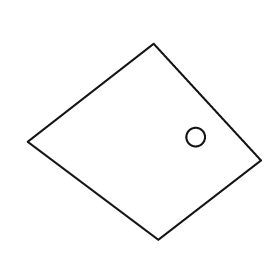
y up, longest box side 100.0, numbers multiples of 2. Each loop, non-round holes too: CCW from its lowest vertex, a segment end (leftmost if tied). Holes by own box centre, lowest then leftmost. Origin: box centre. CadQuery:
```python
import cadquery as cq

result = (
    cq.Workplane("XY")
    .moveTo(6.0, -42.0)
    .lineTo(50.0, -8.0)
    .lineTo(4.0, 42.0)
    .lineTo(-50.0, 0.0)
    .close()
    .moveTo(22.0, 2.0)
    .circle(4.0)
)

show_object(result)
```